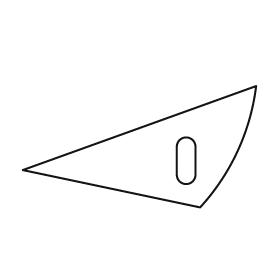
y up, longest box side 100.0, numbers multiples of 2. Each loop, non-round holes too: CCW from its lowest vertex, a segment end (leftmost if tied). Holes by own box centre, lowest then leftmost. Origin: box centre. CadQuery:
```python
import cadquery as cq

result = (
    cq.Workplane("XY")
    .moveTo(26.0, -26.0)
    .threePointArc((42.0, -2.0), (50.0, 26.0))
    .lineTo(-50.0, -10.0)
    .close()
    .moveTo(16.0, -12.0)
    .threePointArc((20.0, -16.0), (24.0, -12.0))
    .lineTo(24.0, 0.0)
    .threePointArc((20.0, 4.0), (16.0, 0.0))
    .close()
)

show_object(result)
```